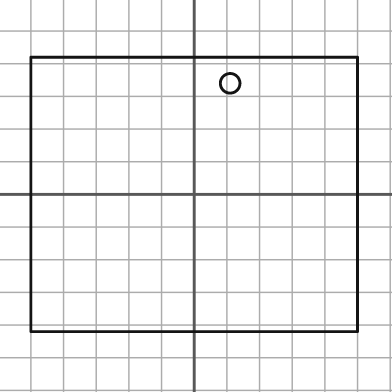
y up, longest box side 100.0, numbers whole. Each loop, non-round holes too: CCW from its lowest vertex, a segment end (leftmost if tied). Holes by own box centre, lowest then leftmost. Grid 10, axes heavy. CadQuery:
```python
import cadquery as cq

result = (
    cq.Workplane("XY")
    .moveTo(-50.0, -42.0)
    .lineTo(50.0, -42.0)
    .lineTo(50.0, 42.0)
    .lineTo(-50.0, 42.0)
    .close()
    .moveTo(11.0, 34.0)
    .circle(3.0)
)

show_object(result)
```